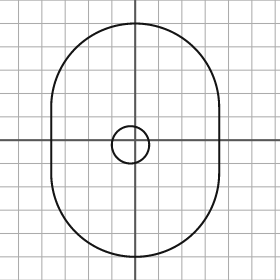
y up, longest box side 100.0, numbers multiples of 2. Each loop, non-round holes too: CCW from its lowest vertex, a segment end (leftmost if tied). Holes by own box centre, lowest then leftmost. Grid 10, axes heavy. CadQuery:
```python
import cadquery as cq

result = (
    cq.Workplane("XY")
    .moveTo(-36.0, -14.0)
    .threePointArc((0.0, -50.0), (36.0, -14.0))
    .lineTo(36.0, 14.0)
    .threePointArc((0.0, 50.0), (-36.0, 14.0))
    .close()
    .moveTo(-2.0, -2.0)
    .circle(8.0)
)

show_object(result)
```